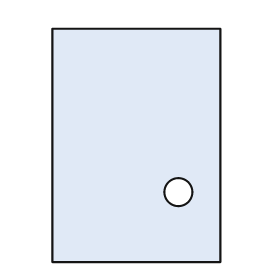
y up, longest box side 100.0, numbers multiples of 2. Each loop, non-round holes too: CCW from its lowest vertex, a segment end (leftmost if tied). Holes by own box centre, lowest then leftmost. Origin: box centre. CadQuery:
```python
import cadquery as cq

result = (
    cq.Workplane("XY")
    .moveTo(-36.0, -50.0)
    .lineTo(36.0, -50.0)
    .lineTo(36.0, 50.0)
    .lineTo(-36.0, 50.0)
    .close()
    .moveTo(18.0, -20.0)
    .circle(6.0)
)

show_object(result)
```